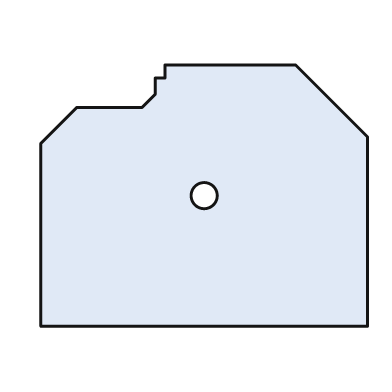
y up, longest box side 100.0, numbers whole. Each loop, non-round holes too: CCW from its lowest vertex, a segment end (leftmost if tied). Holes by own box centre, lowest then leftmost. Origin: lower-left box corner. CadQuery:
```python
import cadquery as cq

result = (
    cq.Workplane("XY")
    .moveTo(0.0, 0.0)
    .lineTo(100.0, 0.0)
    .lineTo(100.0, 58.0)
    .lineTo(78.0, 80.0)
    .lineTo(38.0, 80.0)
    .lineTo(38.0, 76.0)
    .lineTo(35.0, 76.0)
    .lineTo(35.0, 71.0)
    .lineTo(31.0, 67.0)
    .lineTo(11.0, 67.0)
    .lineTo(0.0, 56.0)
    .close()
    .moveTo(50.0, 40.0)
    .circle(4.0)
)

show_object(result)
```